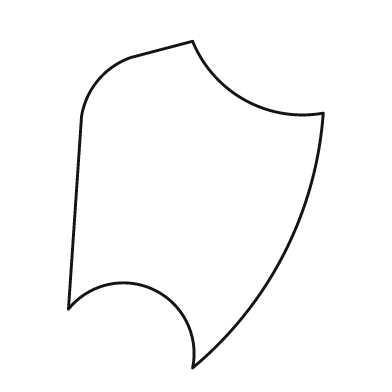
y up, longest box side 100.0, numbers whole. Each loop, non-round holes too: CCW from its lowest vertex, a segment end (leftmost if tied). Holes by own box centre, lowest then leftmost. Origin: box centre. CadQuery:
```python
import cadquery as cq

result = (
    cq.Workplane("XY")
    .moveTo(-1.0, -50.0)
    .threePointArc((27.0, -15.0), (39.0, 28.0))
    .threePointArc((15.0, 32.0), (-1.0, 50.0))
    .lineTo(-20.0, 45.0)
    .threePointArc((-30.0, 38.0), (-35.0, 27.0))
    .lineTo(-39.0, -32.0)
    .threePointArc((-13.0, -26.0), (-1.0, -50.0))
    .close()
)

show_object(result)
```